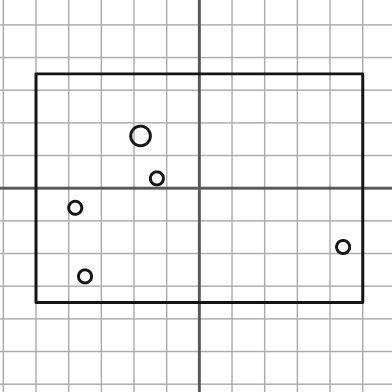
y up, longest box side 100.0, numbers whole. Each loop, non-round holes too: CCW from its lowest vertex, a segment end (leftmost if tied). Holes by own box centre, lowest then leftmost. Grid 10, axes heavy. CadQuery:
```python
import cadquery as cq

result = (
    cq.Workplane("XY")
    .moveTo(-50.0, -35.0)
    .lineTo(50.0, -35.0)
    .lineTo(50.0, 35.0)
    .lineTo(-50.0, 35.0)
    .close()
    .moveTo(-35.0, -27.0)
    .circle(2.0)
    .moveTo(44.0, -18.0)
    .circle(2.0)
    .moveTo(-38.0, -6.0)
    .circle(2.0)
    .moveTo(-13.0, 3.0)
    .circle(2.0)
    .moveTo(-18.0, 16.0)
    .circle(3.0)
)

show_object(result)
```